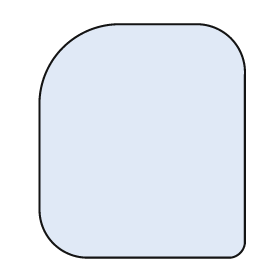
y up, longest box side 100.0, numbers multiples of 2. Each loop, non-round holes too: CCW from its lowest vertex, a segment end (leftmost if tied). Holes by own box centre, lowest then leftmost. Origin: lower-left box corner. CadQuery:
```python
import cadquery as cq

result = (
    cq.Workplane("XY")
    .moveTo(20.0, 0.0)
    .lineTo(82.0, 0.0)
    .threePointArc((86.0, 2.0), (88.0, 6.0))
    .lineTo(88.0, 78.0)
    .threePointArc((82.0, 94.0), (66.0, 100.0))
    .lineTo(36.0, 100.0)
    .threePointArc((10.0, 90.0), (0.0, 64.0))
    .lineTo(0.0, 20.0)
    .threePointArc((6.0, 6.0), (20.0, 0.0))
    .close()
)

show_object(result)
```